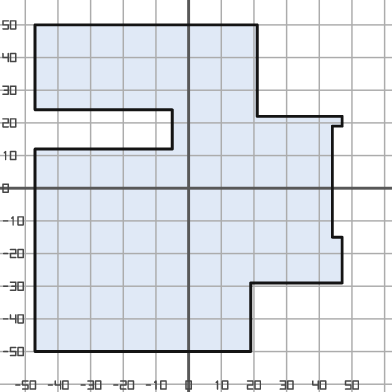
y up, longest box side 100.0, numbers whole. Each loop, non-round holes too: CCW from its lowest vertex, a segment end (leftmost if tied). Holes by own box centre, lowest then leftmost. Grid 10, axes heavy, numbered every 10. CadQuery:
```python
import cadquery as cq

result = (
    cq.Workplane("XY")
    .moveTo(-47.0, -50.0)
    .lineTo(19.0, -50.0)
    .lineTo(19.0, -29.0)
    .lineTo(47.0, -29.0)
    .lineTo(47.0, -15.0)
    .lineTo(44.0, -15.0)
    .lineTo(44.0, 19.0)
    .lineTo(47.0, 19.0)
    .lineTo(47.0, 22.0)
    .lineTo(21.0, 22.0)
    .lineTo(21.0, 50.0)
    .lineTo(-47.0, 50.0)
    .lineTo(-47.0, 24.0)
    .lineTo(-5.0, 24.0)
    .lineTo(-5.0, 12.0)
    .lineTo(-47.0, 12.0)
    .close()
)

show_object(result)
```